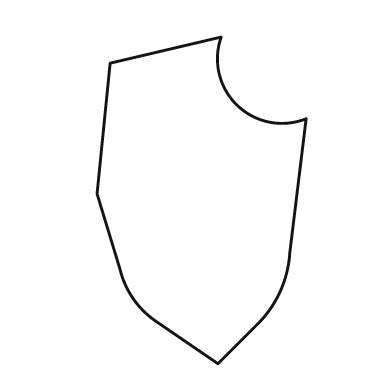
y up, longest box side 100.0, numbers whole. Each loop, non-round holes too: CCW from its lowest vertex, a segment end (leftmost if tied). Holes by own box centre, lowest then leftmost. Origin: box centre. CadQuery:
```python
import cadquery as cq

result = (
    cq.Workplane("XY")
    .moveTo(5.0, -50.0)
    .lineTo(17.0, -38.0)
    .threePointArc((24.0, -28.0), (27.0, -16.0))
    .lineTo(32.0, 25.0)
    .threePointArc((11.0, 29.0), (6.0, 50.0))
    .lineTo(-28.0, 42.0)
    .lineTo(-32.0, 2.0)
    .lineTo(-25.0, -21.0)
    .threePointArc((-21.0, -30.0), (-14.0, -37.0))
    .close()
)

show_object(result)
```